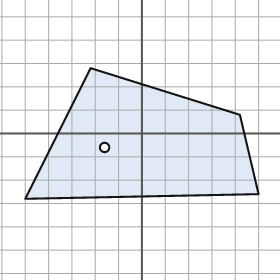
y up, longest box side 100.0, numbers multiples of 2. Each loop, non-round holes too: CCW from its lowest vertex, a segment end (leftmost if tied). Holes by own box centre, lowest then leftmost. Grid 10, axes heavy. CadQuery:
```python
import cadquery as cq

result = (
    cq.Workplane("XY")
    .moveTo(-50.0, -28.0)
    .lineTo(50.0, -26.0)
    .lineTo(42.0, 8.0)
    .lineTo(-22.0, 28.0)
    .close()
    .moveTo(-16.0, -6.0)
    .circle(2.0)
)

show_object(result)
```